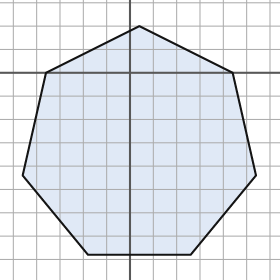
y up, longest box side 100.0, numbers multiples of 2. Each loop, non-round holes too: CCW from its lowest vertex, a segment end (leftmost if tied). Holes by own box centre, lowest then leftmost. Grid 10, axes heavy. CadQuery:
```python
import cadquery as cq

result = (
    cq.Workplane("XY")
    .moveTo(-18.0, -78.0)
    .lineTo(26.0, -78.0)
    .lineTo(54.0, -44.0)
    .lineTo(44.0, 0.0)
    .lineTo(4.0, 20.0)
    .lineTo(-36.0, 0.0)
    .lineTo(-46.0, -44.0)
    .close()
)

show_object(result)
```